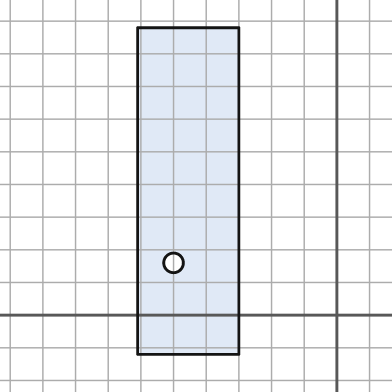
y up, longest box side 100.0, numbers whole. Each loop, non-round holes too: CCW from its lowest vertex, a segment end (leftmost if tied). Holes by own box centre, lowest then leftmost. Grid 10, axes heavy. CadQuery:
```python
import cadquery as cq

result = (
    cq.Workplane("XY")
    .moveTo(-61.0, -12.0)
    .lineTo(-30.0, -12.0)
    .lineTo(-30.0, 88.0)
    .lineTo(-61.0, 88.0)
    .close()
    .moveTo(-50.0, 16.0)
    .circle(3.0)
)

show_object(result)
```